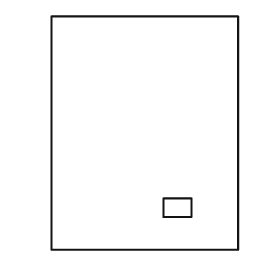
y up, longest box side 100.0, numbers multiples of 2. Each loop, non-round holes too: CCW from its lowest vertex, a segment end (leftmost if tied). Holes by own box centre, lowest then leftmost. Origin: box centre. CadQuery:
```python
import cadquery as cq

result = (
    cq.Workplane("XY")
    .moveTo(-40.0, -50.0)
    .lineTo(40.0, -50.0)
    .lineTo(40.0, 50.0)
    .lineTo(-40.0, 50.0)
    .close()
    .moveTo(8.0, -36.0)
    .lineTo(20.0, -36.0)
    .lineTo(20.0, -28.0)
    .lineTo(8.0, -28.0)
    .close()
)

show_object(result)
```